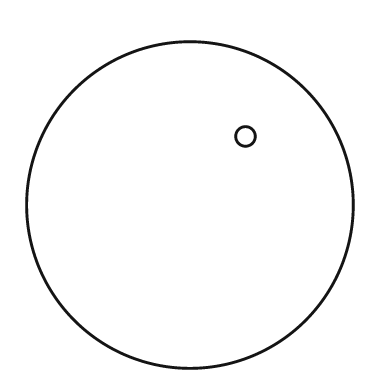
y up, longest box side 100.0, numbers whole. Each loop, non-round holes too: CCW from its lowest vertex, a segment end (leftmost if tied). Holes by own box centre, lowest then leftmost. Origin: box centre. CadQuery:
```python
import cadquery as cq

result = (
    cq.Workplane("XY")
    .moveTo(0.0, 0.0)
    .circle(50.0)
    .moveTo(17.0, 21.0)
    .circle(3.0)
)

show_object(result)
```